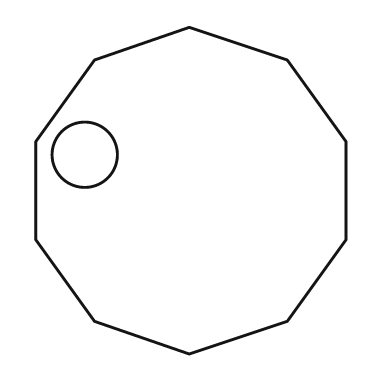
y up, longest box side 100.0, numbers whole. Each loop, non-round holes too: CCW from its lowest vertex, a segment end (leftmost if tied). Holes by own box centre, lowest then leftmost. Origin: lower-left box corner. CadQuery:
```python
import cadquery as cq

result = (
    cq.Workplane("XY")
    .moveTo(47.0, 0.0)
    .lineTo(77.0, 10.0)
    .lineTo(95.0, 35.0)
    .lineTo(95.0, 65.0)
    .lineTo(77.0, 90.0)
    .lineTo(47.0, 100.0)
    .lineTo(18.0, 90.0)
    .lineTo(0.0, 65.0)
    .lineTo(0.0, 35.0)
    .lineTo(18.0, 10.0)
    .close()
    .moveTo(15.0, 61.0)
    .circle(10.0)
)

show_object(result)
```